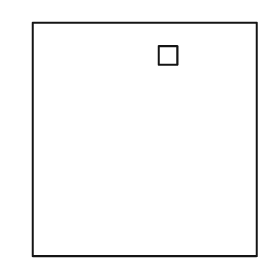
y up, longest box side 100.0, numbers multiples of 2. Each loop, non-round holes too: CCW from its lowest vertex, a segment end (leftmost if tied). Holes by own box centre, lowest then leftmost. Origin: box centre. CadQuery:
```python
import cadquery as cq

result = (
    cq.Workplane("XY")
    .moveTo(-48.0, -50.0)
    .lineTo(48.0, -50.0)
    .lineTo(48.0, 50.0)
    .lineTo(-48.0, 50.0)
    .close()
    .moveTo(6.0, 32.0)
    .lineTo(14.0, 32.0)
    .lineTo(14.0, 40.0)
    .lineTo(6.0, 40.0)
    .close()
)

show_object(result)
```